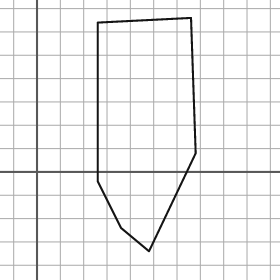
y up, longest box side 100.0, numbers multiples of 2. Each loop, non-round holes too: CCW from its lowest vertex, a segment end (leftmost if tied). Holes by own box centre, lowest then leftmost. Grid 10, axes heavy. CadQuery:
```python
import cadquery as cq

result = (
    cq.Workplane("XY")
    .moveTo(48.0, -34.0)
    .lineTo(68.0, 8.0)
    .lineTo(66.0, 66.0)
    .lineTo(26.0, 64.0)
    .lineTo(26.0, -4.0)
    .lineTo(36.0, -24.0)
    .close()
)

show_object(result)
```